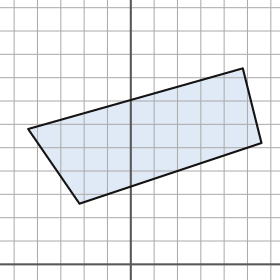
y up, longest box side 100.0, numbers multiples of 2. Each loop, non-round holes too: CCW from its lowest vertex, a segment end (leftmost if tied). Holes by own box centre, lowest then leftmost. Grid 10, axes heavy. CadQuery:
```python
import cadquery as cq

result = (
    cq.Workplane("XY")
    .moveTo(-22.0, 26.0)
    .lineTo(56.0, 52.0)
    .lineTo(48.0, 84.0)
    .lineTo(-44.0, 58.0)
    .close()
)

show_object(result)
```